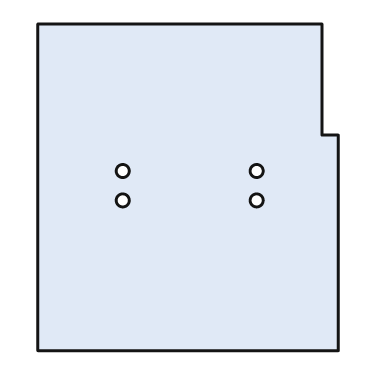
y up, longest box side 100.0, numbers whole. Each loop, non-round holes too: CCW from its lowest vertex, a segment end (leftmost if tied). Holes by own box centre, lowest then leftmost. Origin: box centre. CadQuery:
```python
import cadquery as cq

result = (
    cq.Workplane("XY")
    .moveTo(-46.0, -50.0)
    .lineTo(46.0, -50.0)
    .lineTo(46.0, 16.0)
    .lineTo(41.0, 16.0)
    .lineTo(41.0, 50.0)
    .lineTo(-46.0, 50.0)
    .close()
    .moveTo(-20.0, -4.0)
    .circle(2.0)
    .moveTo(21.0, -4.0)
    .circle(2.0)
    .moveTo(-20.0, 5.0)
    .circle(2.0)
    .moveTo(21.0, 5.0)
    .circle(2.0)
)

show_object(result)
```